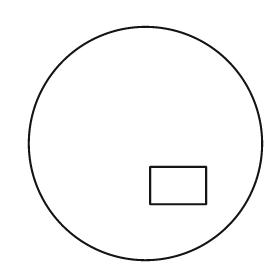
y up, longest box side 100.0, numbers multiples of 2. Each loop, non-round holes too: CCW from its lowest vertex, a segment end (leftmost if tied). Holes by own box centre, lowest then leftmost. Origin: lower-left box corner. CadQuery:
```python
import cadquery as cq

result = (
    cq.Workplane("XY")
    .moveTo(50.0, 50.0)
    .circle(50.0)
    .moveTo(52.0, 24.0)
    .lineTo(76.0, 24.0)
    .lineTo(76.0, 40.0)
    .lineTo(52.0, 40.0)
    .close()
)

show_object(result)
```